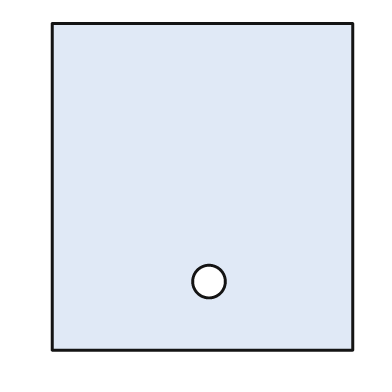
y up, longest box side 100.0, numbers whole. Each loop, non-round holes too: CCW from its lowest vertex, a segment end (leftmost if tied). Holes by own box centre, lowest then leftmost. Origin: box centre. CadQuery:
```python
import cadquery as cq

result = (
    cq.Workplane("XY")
    .moveTo(-46.0, -50.0)
    .lineTo(46.0, -50.0)
    .lineTo(46.0, 50.0)
    .lineTo(-46.0, 50.0)
    .close()
    .moveTo(2.0, -29.0)
    .circle(5.0)
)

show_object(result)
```